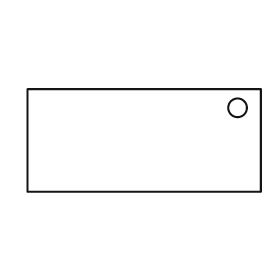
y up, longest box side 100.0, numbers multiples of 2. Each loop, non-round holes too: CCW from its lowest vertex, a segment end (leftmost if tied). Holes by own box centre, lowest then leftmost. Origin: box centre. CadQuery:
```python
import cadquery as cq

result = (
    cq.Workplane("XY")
    .moveTo(-50.0, -22.0)
    .lineTo(50.0, -22.0)
    .lineTo(50.0, 22.0)
    .lineTo(-50.0, 22.0)
    .close()
    .moveTo(40.0, 14.0)
    .circle(4.0)
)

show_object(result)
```